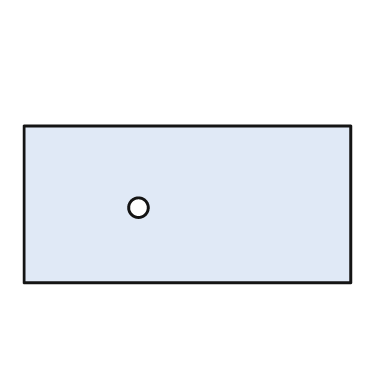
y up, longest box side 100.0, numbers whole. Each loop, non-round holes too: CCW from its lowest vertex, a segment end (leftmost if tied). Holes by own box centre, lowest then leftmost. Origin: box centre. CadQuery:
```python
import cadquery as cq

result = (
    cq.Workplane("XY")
    .moveTo(-50.0, -24.0)
    .lineTo(50.0, -24.0)
    .lineTo(50.0, 24.0)
    .lineTo(-50.0, 24.0)
    .close()
    .moveTo(-15.0, -1.0)
    .circle(3.0)
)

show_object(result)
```